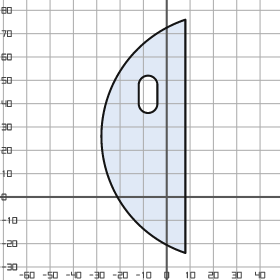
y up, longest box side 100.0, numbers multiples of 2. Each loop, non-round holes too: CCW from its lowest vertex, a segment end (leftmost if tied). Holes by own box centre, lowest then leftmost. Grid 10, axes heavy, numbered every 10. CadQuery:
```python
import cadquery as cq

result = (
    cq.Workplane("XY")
    .moveTo(8.0, -24.0)
    .lineTo(8.0, 76.0)
    .threePointArc((-28.0, 26.0), (8.0, -24.0))
    .close()
    .moveTo(-12.0, 40.0)
    .threePointArc((-8.0, 36.0), (-4.0, 40.0))
    .lineTo(-4.0, 48.0)
    .threePointArc((-8.0, 52.0), (-12.0, 48.0))
    .close()
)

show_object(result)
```